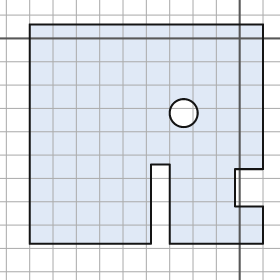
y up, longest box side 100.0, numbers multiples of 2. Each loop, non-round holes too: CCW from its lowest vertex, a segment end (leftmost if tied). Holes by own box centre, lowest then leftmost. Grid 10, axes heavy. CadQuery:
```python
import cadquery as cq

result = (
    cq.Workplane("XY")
    .moveTo(-90.0, -88.0)
    .lineTo(-38.0, -88.0)
    .lineTo(-38.0, -54.0)
    .lineTo(-30.0, -54.0)
    .lineTo(-30.0, -88.0)
    .lineTo(10.0, -88.0)
    .lineTo(10.0, -72.0)
    .lineTo(-2.0, -72.0)
    .lineTo(-2.0, -56.0)
    .lineTo(10.0, -56.0)
    .lineTo(10.0, 6.0)
    .lineTo(-90.0, 6.0)
    .close()
    .moveTo(-24.0, -32.0)
    .circle(6.0)
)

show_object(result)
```